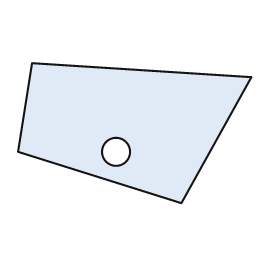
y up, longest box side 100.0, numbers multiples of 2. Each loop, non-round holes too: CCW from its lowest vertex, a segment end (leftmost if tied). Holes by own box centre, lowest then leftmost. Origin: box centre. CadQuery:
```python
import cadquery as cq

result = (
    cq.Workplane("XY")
    .moveTo(20.0, -30.0)
    .lineTo(50.0, 24.0)
    .lineTo(-44.0, 30.0)
    .lineTo(-50.0, -8.0)
    .close()
    .moveTo(-8.0, -8.0)
    .circle(6.0)
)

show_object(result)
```